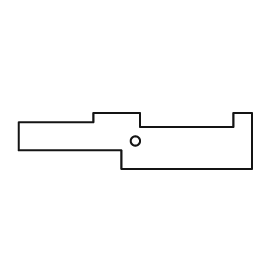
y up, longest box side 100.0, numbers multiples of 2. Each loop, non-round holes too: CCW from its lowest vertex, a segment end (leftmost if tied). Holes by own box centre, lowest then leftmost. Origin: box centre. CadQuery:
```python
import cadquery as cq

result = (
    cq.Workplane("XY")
    .moveTo(-6.0, -12.0)
    .lineTo(50.0, -12.0)
    .lineTo(50.0, 12.0)
    .lineTo(42.0, 12.0)
    .lineTo(42.0, 6.0)
    .lineTo(2.0, 6.0)
    .lineTo(2.0, 12.0)
    .lineTo(-18.0, 12.0)
    .lineTo(-18.0, 8.0)
    .lineTo(-50.0, 8.0)
    .lineTo(-50.0, -4.0)
    .lineTo(-6.0, -4.0)
    .close()
    .moveTo(0.0, 0.0)
    .circle(2.0)
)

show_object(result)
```